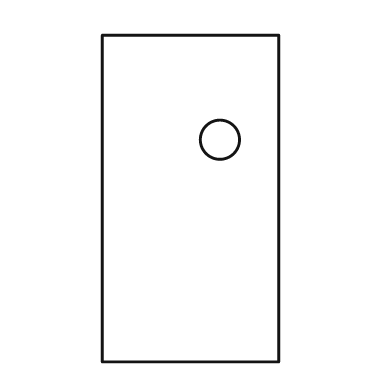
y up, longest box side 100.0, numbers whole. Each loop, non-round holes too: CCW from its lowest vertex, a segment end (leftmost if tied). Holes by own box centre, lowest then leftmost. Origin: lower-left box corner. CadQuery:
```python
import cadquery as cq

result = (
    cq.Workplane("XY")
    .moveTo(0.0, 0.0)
    .lineTo(54.0, 0.0)
    .lineTo(54.0, 100.0)
    .lineTo(0.0, 100.0)
    .close()
    .moveTo(36.0, 68.0)
    .circle(6.0)
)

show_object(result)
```